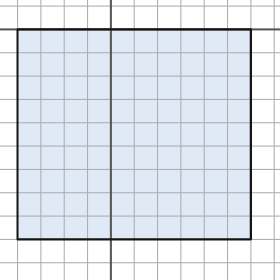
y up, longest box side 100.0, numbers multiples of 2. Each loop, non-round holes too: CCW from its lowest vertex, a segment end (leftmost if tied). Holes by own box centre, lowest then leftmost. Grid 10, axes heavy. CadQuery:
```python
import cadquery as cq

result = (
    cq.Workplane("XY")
    .moveTo(-40.0, -90.0)
    .lineTo(60.0, -90.0)
    .lineTo(60.0, 0.0)
    .lineTo(-40.0, 0.0)
    .close()
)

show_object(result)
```